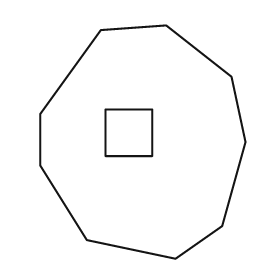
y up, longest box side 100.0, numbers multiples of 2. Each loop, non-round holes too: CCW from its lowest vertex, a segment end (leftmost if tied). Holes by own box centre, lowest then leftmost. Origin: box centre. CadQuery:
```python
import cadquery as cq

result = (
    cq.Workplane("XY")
    .moveTo(14.0, -50.0)
    .lineTo(34.0, -36.0)
    .lineTo(44.0, 0.0)
    .lineTo(38.0, 28.0)
    .lineTo(10.0, 50.0)
    .lineTo(-18.0, 48.0)
    .lineTo(-44.0, 12.0)
    .lineTo(-44.0, -10.0)
    .lineTo(-24.0, -42.0)
    .close()
    .moveTo(-16.0, -6.0)
    .lineTo(4.0, -6.0)
    .lineTo(4.0, 14.0)
    .lineTo(-16.0, 14.0)
    .close()
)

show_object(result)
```